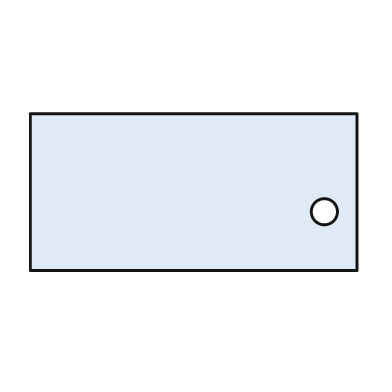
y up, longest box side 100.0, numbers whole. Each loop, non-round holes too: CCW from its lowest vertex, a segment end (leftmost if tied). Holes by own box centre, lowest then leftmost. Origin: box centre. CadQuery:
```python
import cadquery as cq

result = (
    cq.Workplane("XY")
    .moveTo(-50.0, -24.0)
    .lineTo(50.0, -24.0)
    .lineTo(50.0, 24.0)
    .lineTo(-50.0, 24.0)
    .close()
    .moveTo(40.0, -6.0)
    .circle(4.0)
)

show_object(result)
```